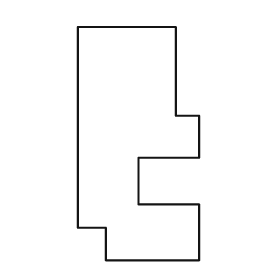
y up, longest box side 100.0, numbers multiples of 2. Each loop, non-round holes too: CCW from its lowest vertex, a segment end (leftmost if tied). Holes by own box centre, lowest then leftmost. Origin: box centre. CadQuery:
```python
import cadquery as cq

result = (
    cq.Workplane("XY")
    .moveTo(-14.0, -50.0)
    .lineTo(26.0, -50.0)
    .lineTo(26.0, -26.0)
    .lineTo(0.0, -26.0)
    .lineTo(0.0, -6.0)
    .lineTo(26.0, -6.0)
    .lineTo(26.0, 12.0)
    .lineTo(16.0, 12.0)
    .lineTo(16.0, 50.0)
    .lineTo(-26.0, 50.0)
    .lineTo(-26.0, -36.0)
    .lineTo(-14.0, -36.0)
    .close()
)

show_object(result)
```